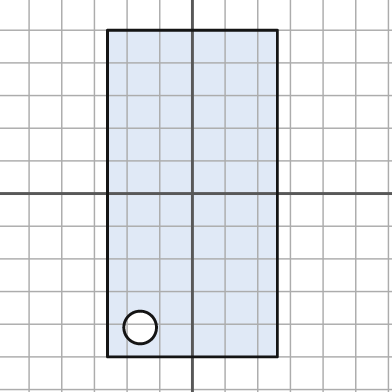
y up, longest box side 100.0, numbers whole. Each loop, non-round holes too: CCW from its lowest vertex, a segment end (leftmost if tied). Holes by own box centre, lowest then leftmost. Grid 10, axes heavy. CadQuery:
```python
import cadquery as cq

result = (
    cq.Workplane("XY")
    .moveTo(-26.0, -50.0)
    .lineTo(26.0, -50.0)
    .lineTo(26.0, 50.0)
    .lineTo(-26.0, 50.0)
    .close()
    .moveTo(-16.0, -41.0)
    .circle(5.0)
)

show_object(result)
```